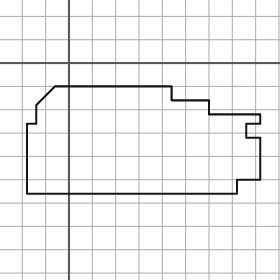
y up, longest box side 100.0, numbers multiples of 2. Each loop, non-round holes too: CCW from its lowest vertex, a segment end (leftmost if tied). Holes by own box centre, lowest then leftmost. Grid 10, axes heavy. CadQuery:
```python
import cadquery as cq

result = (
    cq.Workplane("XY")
    .moveTo(-18.0, -56.0)
    .lineTo(72.0, -56.0)
    .lineTo(72.0, -50.0)
    .lineTo(82.0, -50.0)
    .lineTo(82.0, -32.0)
    .lineTo(76.0, -32.0)
    .lineTo(76.0, -26.0)
    .lineTo(82.0, -26.0)
    .lineTo(82.0, -22.0)
    .lineTo(60.0, -22.0)
    .lineTo(60.0, -16.0)
    .lineTo(44.0, -16.0)
    .lineTo(44.0, -10.0)
    .lineTo(-6.0, -10.0)
    .lineTo(-14.0, -18.0)
    .lineTo(-14.0, -26.0)
    .lineTo(-18.0, -26.0)
    .close()
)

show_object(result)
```